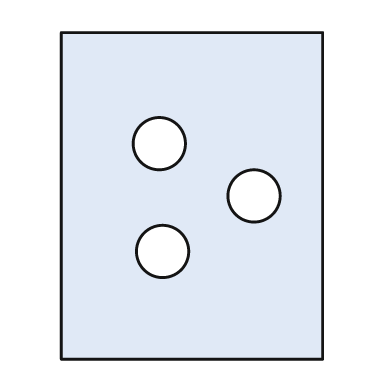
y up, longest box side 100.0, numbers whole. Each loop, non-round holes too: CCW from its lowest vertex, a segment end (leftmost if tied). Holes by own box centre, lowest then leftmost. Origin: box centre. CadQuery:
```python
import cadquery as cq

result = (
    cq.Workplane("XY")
    .moveTo(-40.0, -50.0)
    .lineTo(40.0, -50.0)
    .lineTo(40.0, 50.0)
    .lineTo(-40.0, 50.0)
    .close()
    .moveTo(-9.0, -17.0)
    .circle(8.0)
    .moveTo(19.0, 0.0)
    .circle(8.0)
    .moveTo(-10.0, 16.0)
    .circle(8.0)
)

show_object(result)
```